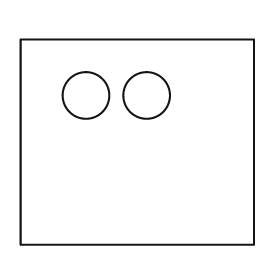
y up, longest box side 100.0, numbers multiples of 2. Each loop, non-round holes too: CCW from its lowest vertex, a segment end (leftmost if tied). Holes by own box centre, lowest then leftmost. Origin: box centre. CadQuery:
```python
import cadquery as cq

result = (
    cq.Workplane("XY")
    .moveTo(-50.0, -44.0)
    .lineTo(50.0, -44.0)
    .lineTo(50.0, 44.0)
    .lineTo(-50.0, 44.0)
    .close()
    .moveTo(-22.0, 20.0)
    .circle(10.0)
    .moveTo(4.0, 20.0)
    .circle(10.0)
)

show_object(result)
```